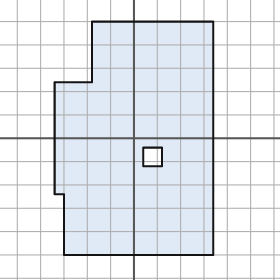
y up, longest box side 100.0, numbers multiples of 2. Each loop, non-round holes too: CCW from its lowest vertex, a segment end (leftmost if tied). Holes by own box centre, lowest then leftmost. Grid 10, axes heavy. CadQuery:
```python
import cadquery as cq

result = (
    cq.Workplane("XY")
    .moveTo(-30.0, -50.0)
    .lineTo(34.0, -50.0)
    .lineTo(34.0, 50.0)
    .lineTo(-18.0, 50.0)
    .lineTo(-18.0, 24.0)
    .lineTo(-34.0, 24.0)
    .lineTo(-34.0, -24.0)
    .lineTo(-30.0, -24.0)
    .close()
    .moveTo(4.0, -12.0)
    .lineTo(12.0, -12.0)
    .lineTo(12.0, -4.0)
    .lineTo(4.0, -4.0)
    .close()
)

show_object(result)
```